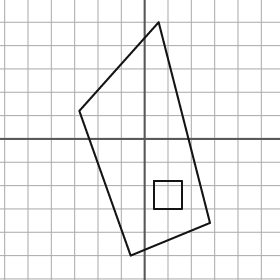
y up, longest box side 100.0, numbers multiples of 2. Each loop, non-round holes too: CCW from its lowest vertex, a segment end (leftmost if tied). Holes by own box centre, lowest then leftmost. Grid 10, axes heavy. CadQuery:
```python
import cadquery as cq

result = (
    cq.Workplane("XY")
    .moveTo(-6.0, -50.0)
    .lineTo(28.0, -36.0)
    .lineTo(6.0, 50.0)
    .lineTo(-28.0, 12.0)
    .close()
    .moveTo(4.0, -30.0)
    .lineTo(16.0, -30.0)
    .lineTo(16.0, -18.0)
    .lineTo(4.0, -18.0)
    .close()
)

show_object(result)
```